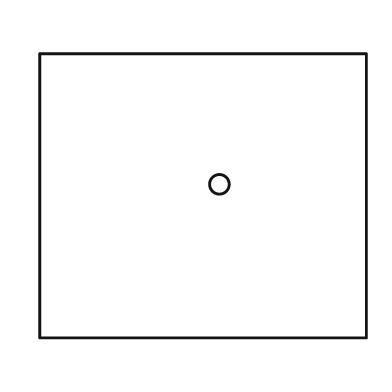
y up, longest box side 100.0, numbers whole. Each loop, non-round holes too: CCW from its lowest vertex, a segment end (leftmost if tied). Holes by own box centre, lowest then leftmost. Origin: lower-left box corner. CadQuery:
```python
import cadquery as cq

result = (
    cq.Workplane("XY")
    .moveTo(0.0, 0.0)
    .lineTo(100.0, 0.0)
    .lineTo(100.0, 87.0)
    .lineTo(0.0, 87.0)
    .close()
    .moveTo(55.0, 47.0)
    .circle(3.0)
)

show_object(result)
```